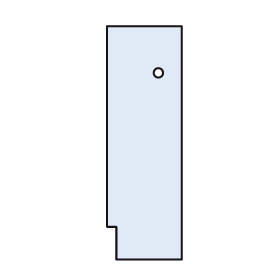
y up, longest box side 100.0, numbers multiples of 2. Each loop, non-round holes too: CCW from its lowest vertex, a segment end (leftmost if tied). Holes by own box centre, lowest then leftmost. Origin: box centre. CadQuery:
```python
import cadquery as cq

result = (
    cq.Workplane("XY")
    .moveTo(-12.0, -50.0)
    .lineTo(16.0, -50.0)
    .lineTo(16.0, 50.0)
    .lineTo(-16.0, 50.0)
    .lineTo(-16.0, -36.0)
    .lineTo(-12.0, -36.0)
    .close()
    .moveTo(6.0, 30.0)
    .circle(2.0)
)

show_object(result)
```